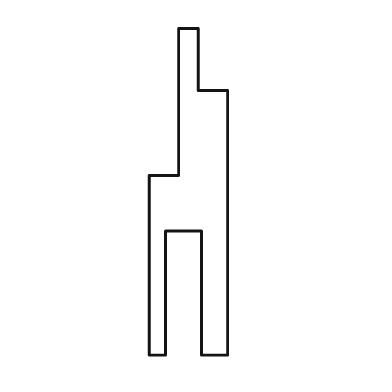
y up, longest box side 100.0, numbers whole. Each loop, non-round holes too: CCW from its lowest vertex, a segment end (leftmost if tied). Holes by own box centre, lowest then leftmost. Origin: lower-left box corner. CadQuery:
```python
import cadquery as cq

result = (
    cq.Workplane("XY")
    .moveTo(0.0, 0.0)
    .lineTo(5.0, 0.0)
    .lineTo(5.0, 38.0)
    .lineTo(16.0, 38.0)
    .lineTo(16.0, 0.0)
    .lineTo(24.0, 0.0)
    .lineTo(24.0, 81.0)
    .lineTo(15.0, 81.0)
    .lineTo(15.0, 100.0)
    .lineTo(9.0, 100.0)
    .lineTo(9.0, 55.0)
    .lineTo(0.0, 55.0)
    .close()
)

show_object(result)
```